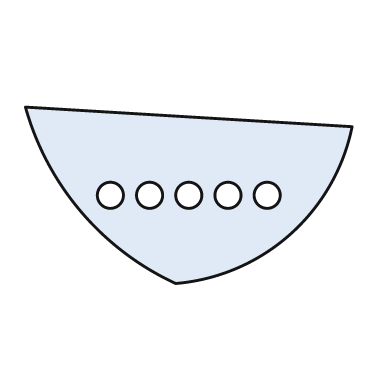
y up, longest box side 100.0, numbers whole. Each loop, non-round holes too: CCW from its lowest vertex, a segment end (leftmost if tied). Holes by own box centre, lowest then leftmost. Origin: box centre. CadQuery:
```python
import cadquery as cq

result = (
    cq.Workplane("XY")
    .moveTo(-4.0, -27.0)
    .threePointArc((31.0, -12.0), (50.0, 21.0))
    .lineTo(-50.0, 27.0)
    .threePointArc((-33.0, -5.0), (-4.0, -27.0))
    .close()
    .moveTo(-24.0, 0.0)
    .circle(4.0)
    .moveTo(-12.0, 0.0)
    .circle(4.0)
    .moveTo(0.0, 0.0)
    .circle(4.0)
    .moveTo(12.0, 0.0)
    .circle(4.0)
    .moveTo(24.0, 0.0)
    .circle(4.0)
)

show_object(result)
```